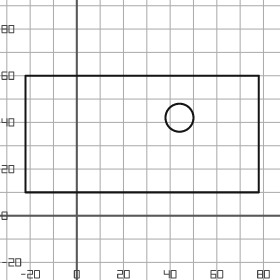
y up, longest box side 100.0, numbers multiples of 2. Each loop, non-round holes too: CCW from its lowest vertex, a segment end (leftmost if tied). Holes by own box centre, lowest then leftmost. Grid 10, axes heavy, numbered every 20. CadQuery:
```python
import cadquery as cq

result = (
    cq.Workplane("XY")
    .moveTo(-22.0, 10.0)
    .lineTo(78.0, 10.0)
    .lineTo(78.0, 60.0)
    .lineTo(-22.0, 60.0)
    .close()
    .moveTo(44.0, 42.0)
    .circle(6.0)
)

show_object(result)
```